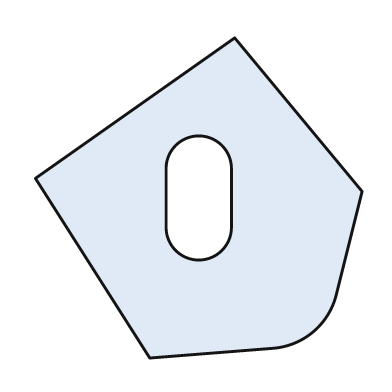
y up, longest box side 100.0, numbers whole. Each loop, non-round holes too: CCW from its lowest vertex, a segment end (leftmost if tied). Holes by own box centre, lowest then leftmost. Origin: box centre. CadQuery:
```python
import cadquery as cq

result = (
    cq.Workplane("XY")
    .moveTo(-15.0, -49.0)
    .lineTo(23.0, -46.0)
    .threePointArc((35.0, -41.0), (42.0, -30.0))
    .lineTo(50.0, 2.0)
    .lineTo(11.0, 49.0)
    .lineTo(-50.0, 6.0)
    .close()
    .moveTo(-10.0, -9.0)
    .threePointArc((0.0, -19.0), (10.0, -9.0))
    .lineTo(10.0, 9.0)
    .threePointArc((0.0, 19.0), (-10.0, 9.0))
    .close()
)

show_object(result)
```